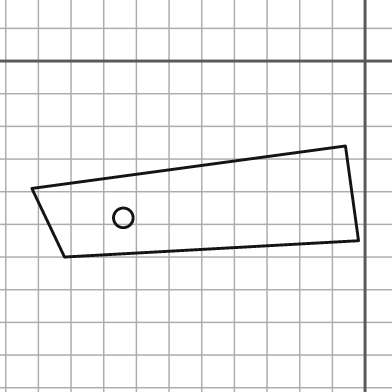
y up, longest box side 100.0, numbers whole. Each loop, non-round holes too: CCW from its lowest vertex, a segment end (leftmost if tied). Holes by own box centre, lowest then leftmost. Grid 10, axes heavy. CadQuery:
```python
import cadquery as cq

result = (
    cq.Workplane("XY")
    .moveTo(-92.0, -60.0)
    .lineTo(-2.0, -55.0)
    .lineTo(-6.0, -26.0)
    .lineTo(-102.0, -39.0)
    .close()
    .moveTo(-74.0, -48.0)
    .circle(3.0)
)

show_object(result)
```